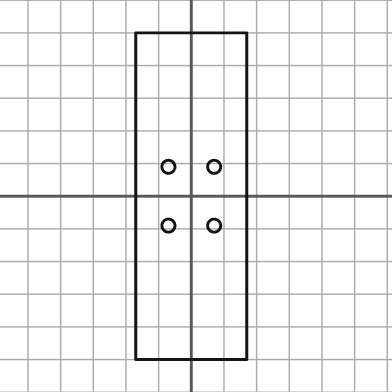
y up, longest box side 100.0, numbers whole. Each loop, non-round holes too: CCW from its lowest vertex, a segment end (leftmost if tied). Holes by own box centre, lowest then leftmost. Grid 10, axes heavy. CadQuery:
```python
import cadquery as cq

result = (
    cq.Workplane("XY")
    .moveTo(-17.0, -50.0)
    .lineTo(17.0, -50.0)
    .lineTo(17.0, 50.0)
    .lineTo(-17.0, 50.0)
    .close()
    .moveTo(-7.0, -9.0)
    .circle(2.0)
    .moveTo(7.0, -9.0)
    .circle(2.0)
    .moveTo(-7.0, 9.0)
    .circle(2.0)
    .moveTo(7.0, 9.0)
    .circle(2.0)
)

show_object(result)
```